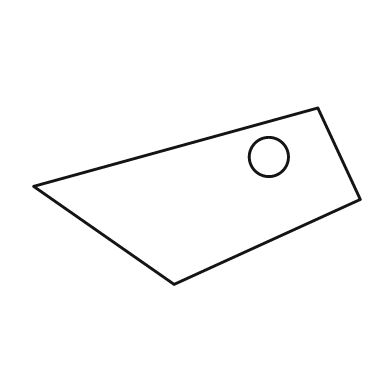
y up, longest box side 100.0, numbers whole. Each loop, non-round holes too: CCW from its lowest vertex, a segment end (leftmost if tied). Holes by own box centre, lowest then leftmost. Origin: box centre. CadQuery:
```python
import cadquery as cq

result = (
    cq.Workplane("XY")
    .moveTo(-7.0, -27.0)
    .lineTo(50.0, -1.0)
    .lineTo(37.0, 27.0)
    .lineTo(-50.0, 3.0)
    .close()
    .moveTo(22.0, 12.0)
    .circle(6.0)
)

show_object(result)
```